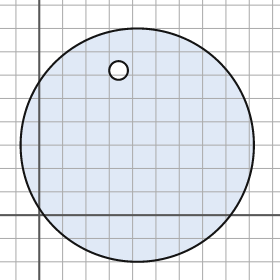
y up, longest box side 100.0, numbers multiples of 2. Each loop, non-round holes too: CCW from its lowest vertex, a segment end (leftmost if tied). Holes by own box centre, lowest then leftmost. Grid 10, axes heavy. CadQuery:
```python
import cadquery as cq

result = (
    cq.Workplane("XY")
    .moveTo(42.0, 30.0)
    .circle(50.0)
    .moveTo(34.0, 62.0)
    .circle(4.0)
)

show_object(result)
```